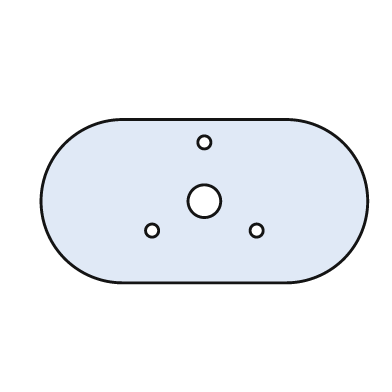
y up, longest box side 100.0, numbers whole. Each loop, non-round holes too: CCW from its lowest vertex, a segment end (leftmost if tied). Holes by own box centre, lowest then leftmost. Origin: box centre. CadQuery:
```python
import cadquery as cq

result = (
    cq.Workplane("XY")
    .moveTo(-25.0, -25.0)
    .lineTo(25.0, -25.0)
    .threePointArc((50.0, 0.0), (25.0, 25.0))
    .lineTo(-25.0, 25.0)
    .threePointArc((-50.0, 0.0), (-25.0, -25.0))
    .close()
    .moveTo(-16.0, -9.0)
    .circle(2.0)
    .moveTo(16.0, -9.0)
    .circle(2.0)
    .moveTo(0.0, 0.0)
    .circle(5.0)
    .moveTo(0.0, 18.0)
    .circle(2.0)
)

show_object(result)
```